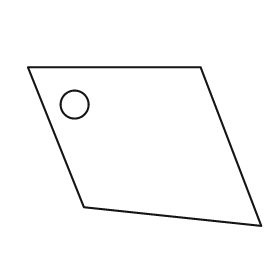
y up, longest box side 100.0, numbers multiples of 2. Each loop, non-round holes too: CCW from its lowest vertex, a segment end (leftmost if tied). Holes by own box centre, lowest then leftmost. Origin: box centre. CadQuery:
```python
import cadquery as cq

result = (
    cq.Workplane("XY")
    .moveTo(50.0, -34.0)
    .lineTo(24.0, 34.0)
    .lineTo(-50.0, 34.0)
    .lineTo(-26.0, -26.0)
    .close()
    .moveTo(-30.0, 18.0)
    .circle(6.0)
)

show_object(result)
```